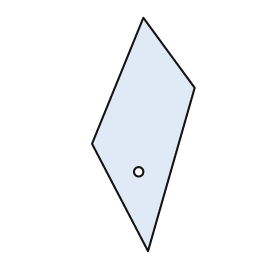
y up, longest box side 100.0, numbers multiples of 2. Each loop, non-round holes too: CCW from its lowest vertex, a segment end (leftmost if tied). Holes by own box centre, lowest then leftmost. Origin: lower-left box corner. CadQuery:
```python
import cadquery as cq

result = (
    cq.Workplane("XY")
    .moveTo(24.0, 0.0)
    .lineTo(44.0, 70.0)
    .lineTo(22.0, 100.0)
    .lineTo(0.0, 46.0)
    .close()
    .moveTo(20.0, 34.0)
    .circle(2.0)
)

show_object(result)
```